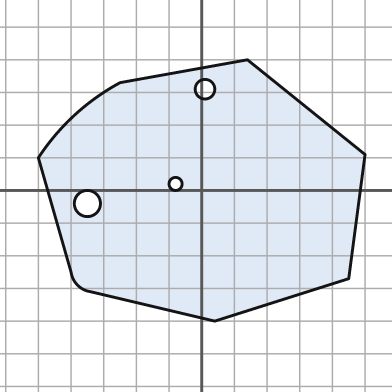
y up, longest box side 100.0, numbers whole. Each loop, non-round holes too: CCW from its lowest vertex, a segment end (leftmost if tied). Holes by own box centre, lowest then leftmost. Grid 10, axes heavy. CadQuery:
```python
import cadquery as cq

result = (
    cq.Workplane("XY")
    .moveTo(4.0, -40.0)
    .lineTo(45.0, -27.0)
    .lineTo(50.0, 11.0)
    .lineTo(14.0, 40.0)
    .lineTo(-25.0, 33.0)
    .threePointArc((-39.0, 23.0), (-50.0, 10.0))
    .lineTo(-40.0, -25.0)
    .threePointArc((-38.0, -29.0), (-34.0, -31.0))
    .close()
    .moveTo(-35.0, -4.0)
    .circle(4.0)
    .moveTo(-8.0, 2.0)
    .circle(2.0)
    .moveTo(1.0, 31.0)
    .circle(3.0)
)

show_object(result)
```